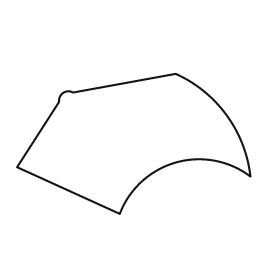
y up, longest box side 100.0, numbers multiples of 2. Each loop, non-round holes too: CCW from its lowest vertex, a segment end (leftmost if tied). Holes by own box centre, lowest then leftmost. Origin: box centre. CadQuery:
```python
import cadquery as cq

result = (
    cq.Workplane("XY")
    .moveTo(-6.0, -30.0)
    .threePointArc((18.0, -8.0), (50.0, -14.0))
    .threePointArc((40.0, 12.0), (18.0, 30.0))
    .lineTo(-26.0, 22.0)
    .threePointArc((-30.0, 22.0), (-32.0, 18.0))
    .lineTo(-50.0, -10.0)
    .close()
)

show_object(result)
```